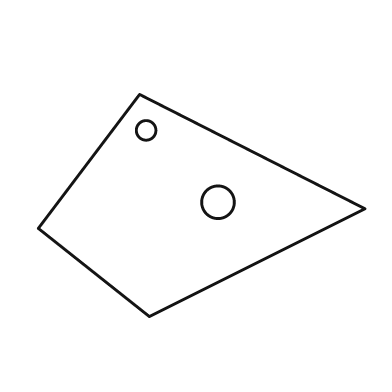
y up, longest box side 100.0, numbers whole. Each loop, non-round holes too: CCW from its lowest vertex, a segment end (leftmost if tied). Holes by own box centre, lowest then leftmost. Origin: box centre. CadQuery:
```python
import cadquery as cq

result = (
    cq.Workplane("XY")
    .moveTo(-16.0, -34.0)
    .lineTo(50.0, -1.0)
    .lineTo(-19.0, 34.0)
    .lineTo(-50.0, -7.0)
    .close()
    .moveTo(5.0, 1.0)
    .circle(5.0)
    .moveTo(-17.0, 23.0)
    .circle(3.0)
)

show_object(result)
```